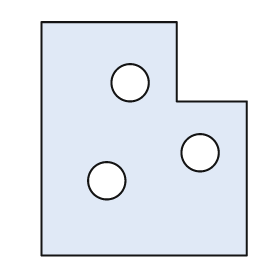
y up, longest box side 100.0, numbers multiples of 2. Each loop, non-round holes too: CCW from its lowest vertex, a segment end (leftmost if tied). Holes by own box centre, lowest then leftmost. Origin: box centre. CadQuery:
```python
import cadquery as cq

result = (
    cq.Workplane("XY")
    .moveTo(-44.0, -50.0)
    .lineTo(44.0, -50.0)
    .lineTo(44.0, 16.0)
    .lineTo(14.0, 16.0)
    .lineTo(14.0, 50.0)
    .lineTo(-44.0, 50.0)
    .close()
    .moveTo(-16.0, -18.0)
    .circle(8.0)
    .moveTo(24.0, -6.0)
    .circle(8.0)
    .moveTo(-6.0, 24.0)
    .circle(8.0)
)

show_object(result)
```